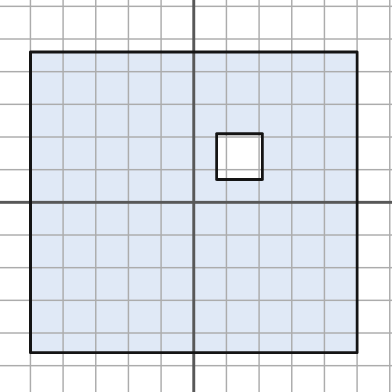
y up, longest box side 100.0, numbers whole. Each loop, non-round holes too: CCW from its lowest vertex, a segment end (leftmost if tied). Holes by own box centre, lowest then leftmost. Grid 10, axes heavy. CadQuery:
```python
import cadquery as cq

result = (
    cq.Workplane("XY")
    .moveTo(-50.0, -46.0)
    .lineTo(50.0, -46.0)
    .lineTo(50.0, 46.0)
    .lineTo(-50.0, 46.0)
    .close()
    .moveTo(7.0, 7.0)
    .lineTo(21.0, 7.0)
    .lineTo(21.0, 21.0)
    .lineTo(7.0, 21.0)
    .close()
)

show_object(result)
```